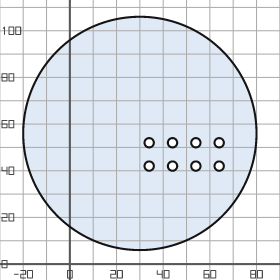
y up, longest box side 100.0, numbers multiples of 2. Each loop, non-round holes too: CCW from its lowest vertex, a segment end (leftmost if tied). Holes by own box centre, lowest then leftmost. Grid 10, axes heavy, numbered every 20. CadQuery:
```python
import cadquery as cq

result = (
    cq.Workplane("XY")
    .moveTo(30.0, 56.0)
    .circle(50.0)
    .moveTo(34.0, 42.0)
    .circle(2.0)
    .moveTo(44.0, 42.0)
    .circle(2.0)
    .moveTo(54.0, 42.0)
    .circle(2.0)
    .moveTo(64.0, 42.0)
    .circle(2.0)
    .moveTo(34.0, 52.0)
    .circle(2.0)
    .moveTo(44.0, 52.0)
    .circle(2.0)
    .moveTo(54.0, 52.0)
    .circle(2.0)
    .moveTo(64.0, 52.0)
    .circle(2.0)
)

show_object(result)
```